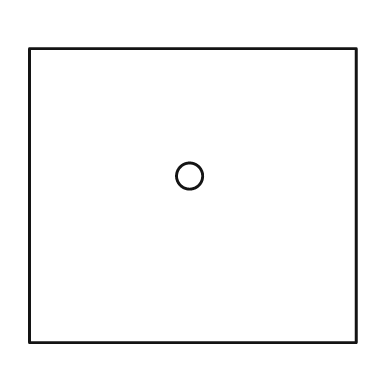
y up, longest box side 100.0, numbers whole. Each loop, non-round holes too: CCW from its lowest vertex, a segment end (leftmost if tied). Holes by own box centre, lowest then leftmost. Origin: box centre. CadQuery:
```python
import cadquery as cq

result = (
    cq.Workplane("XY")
    .moveTo(-50.0, -45.0)
    .lineTo(50.0, -45.0)
    .lineTo(50.0, 45.0)
    .lineTo(-50.0, 45.0)
    .close()
    .moveTo(-1.0, 6.0)
    .circle(4.0)
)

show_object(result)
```